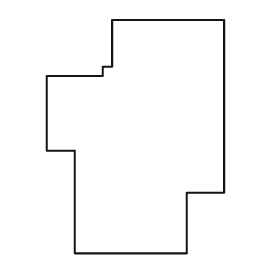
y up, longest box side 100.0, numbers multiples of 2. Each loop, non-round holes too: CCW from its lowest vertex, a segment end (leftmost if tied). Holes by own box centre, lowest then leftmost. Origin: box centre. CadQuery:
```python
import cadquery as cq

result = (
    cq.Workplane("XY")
    .moveTo(-26.0, -50.0)
    .lineTo(22.0, -50.0)
    .lineTo(22.0, -24.0)
    .lineTo(38.0, -24.0)
    .lineTo(38.0, 50.0)
    .lineTo(-10.0, 50.0)
    .lineTo(-10.0, 30.0)
    .lineTo(-14.0, 30.0)
    .lineTo(-14.0, 26.0)
    .lineTo(-38.0, 26.0)
    .lineTo(-38.0, -6.0)
    .lineTo(-26.0, -6.0)
    .close()
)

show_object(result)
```